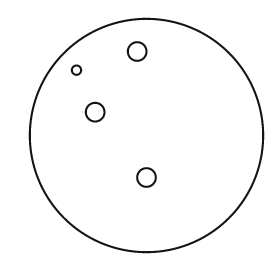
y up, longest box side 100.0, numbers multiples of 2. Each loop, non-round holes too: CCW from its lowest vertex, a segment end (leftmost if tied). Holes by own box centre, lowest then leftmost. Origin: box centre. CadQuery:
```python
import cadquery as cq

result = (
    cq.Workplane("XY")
    .moveTo(0.0, 0.0)
    .circle(50.0)
    .moveTo(0.0, -18.0)
    .circle(4.0)
    .moveTo(-22.0, 10.0)
    .circle(4.0)
    .moveTo(-30.0, 28.0)
    .circle(2.0)
    .moveTo(-4.0, 36.0)
    .circle(4.0)
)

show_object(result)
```